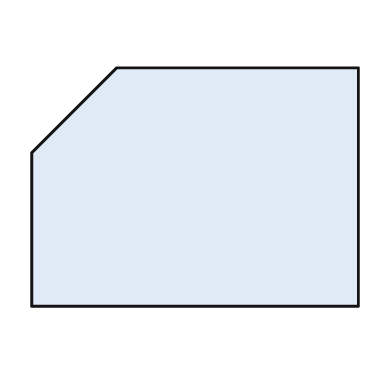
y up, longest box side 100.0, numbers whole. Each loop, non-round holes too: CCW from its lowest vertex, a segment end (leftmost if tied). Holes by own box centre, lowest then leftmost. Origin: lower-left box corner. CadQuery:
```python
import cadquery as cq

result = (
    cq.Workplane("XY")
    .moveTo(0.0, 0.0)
    .lineTo(100.0, 0.0)
    .lineTo(100.0, 73.0)
    .lineTo(26.0, 73.0)
    .lineTo(0.0, 47.0)
    .close()
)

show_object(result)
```